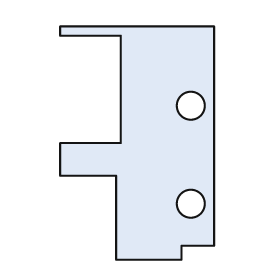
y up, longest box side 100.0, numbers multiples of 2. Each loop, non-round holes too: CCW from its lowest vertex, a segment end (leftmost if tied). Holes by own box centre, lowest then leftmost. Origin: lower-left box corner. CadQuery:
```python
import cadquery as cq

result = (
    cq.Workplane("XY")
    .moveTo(24.0, 0.0)
    .lineTo(52.0, 0.0)
    .lineTo(52.0, 6.0)
    .lineTo(66.0, 6.0)
    .lineTo(66.0, 100.0)
    .lineTo(0.0, 100.0)
    .lineTo(0.0, 96.0)
    .lineTo(26.0, 96.0)
    .lineTo(26.0, 50.0)
    .lineTo(0.0, 50.0)
    .lineTo(0.0, 36.0)
    .lineTo(24.0, 36.0)
    .close()
    .moveTo(56.0, 24.0)
    .circle(6.0)
    .moveTo(56.0, 66.0)
    .circle(6.0)
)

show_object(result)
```